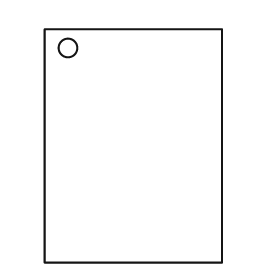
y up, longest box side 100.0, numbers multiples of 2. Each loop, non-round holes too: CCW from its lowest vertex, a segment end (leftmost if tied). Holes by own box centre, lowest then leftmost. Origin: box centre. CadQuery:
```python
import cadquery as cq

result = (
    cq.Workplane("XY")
    .moveTo(-38.0, -50.0)
    .lineTo(38.0, -50.0)
    .lineTo(38.0, 50.0)
    .lineTo(-38.0, 50.0)
    .close()
    .moveTo(-28.0, 42.0)
    .circle(4.0)
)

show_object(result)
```